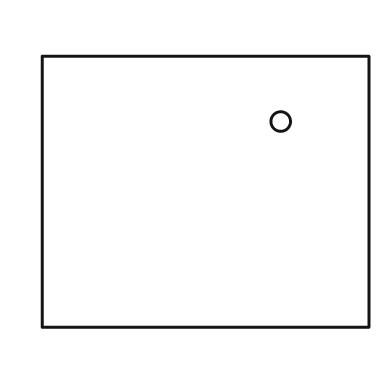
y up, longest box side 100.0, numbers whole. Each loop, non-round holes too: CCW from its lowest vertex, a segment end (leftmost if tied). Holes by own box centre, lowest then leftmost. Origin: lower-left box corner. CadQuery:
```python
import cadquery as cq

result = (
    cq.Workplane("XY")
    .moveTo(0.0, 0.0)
    .lineTo(100.0, 0.0)
    .lineTo(100.0, 83.0)
    .lineTo(0.0, 83.0)
    .close()
    .moveTo(73.0, 63.0)
    .circle(3.0)
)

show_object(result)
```